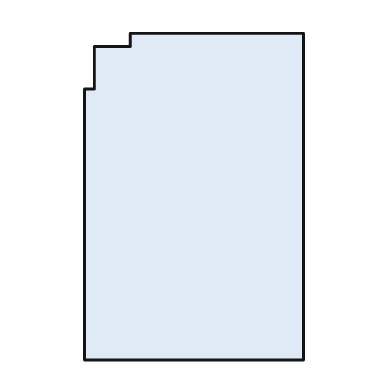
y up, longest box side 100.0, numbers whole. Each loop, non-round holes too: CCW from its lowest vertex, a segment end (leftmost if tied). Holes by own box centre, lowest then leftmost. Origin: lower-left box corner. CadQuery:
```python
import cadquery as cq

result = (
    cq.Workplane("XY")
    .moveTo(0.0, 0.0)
    .lineTo(67.0, 0.0)
    .lineTo(67.0, 100.0)
    .lineTo(14.0, 100.0)
    .lineTo(14.0, 96.0)
    .lineTo(3.0, 96.0)
    .lineTo(3.0, 83.0)
    .lineTo(0.0, 83.0)
    .close()
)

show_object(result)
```